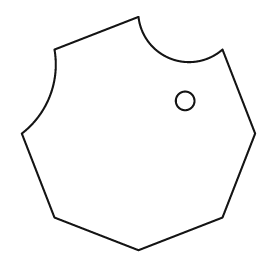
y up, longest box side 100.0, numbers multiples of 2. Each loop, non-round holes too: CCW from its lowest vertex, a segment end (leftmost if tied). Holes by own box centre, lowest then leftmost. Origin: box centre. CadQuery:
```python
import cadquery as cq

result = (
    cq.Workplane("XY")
    .moveTo(0.0, -50.0)
    .lineTo(36.0, -36.0)
    .lineTo(50.0, 0.0)
    .lineTo(36.0, 36.0)
    .threePointArc((14.0, 32.0), (0.0, 50.0))
    .lineTo(-36.0, 36.0)
    .threePointArc((-38.0, 16.0), (-50.0, 0.0))
    .lineTo(-36.0, -36.0)
    .close()
    .moveTo(20.0, 14.0)
    .circle(4.0)
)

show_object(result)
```